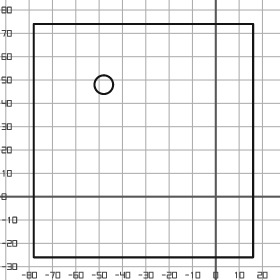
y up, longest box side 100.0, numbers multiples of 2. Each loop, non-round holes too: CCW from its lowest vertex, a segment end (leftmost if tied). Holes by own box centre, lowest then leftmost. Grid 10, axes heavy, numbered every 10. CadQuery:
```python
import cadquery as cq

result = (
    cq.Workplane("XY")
    .moveTo(-78.0, -26.0)
    .lineTo(16.0, -26.0)
    .lineTo(16.0, 74.0)
    .lineTo(-78.0, 74.0)
    .close()
    .moveTo(-48.0, 48.0)
    .circle(4.0)
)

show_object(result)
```